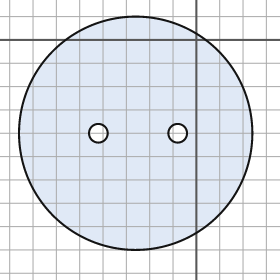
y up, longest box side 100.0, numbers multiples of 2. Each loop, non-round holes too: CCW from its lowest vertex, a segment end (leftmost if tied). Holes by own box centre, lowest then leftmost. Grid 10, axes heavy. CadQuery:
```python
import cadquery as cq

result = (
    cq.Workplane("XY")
    .moveTo(-26.0, -40.0)
    .circle(50.0)
    .moveTo(-42.0, -40.0)
    .circle(4.0)
    .moveTo(-8.0, -40.0)
    .circle(4.0)
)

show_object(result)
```